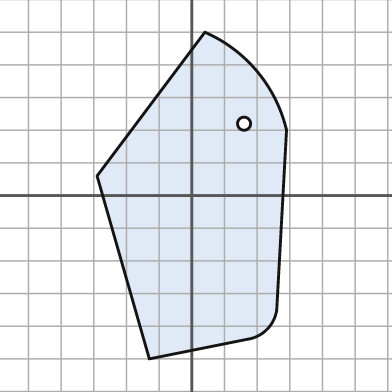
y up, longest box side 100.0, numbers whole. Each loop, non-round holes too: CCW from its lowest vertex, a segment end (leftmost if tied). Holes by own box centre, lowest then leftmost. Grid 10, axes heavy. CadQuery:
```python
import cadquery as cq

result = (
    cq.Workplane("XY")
    .moveTo(-13.0, -50.0)
    .lineTo(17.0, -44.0)
    .threePointArc((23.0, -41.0), (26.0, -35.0))
    .lineTo(29.0, 20.0)
    .threePointArc((20.0, 38.0), (4.0, 50.0))
    .lineTo(-29.0, 6.0)
    .close()
    .moveTo(16.0, 22.0)
    .circle(2.0)
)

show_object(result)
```